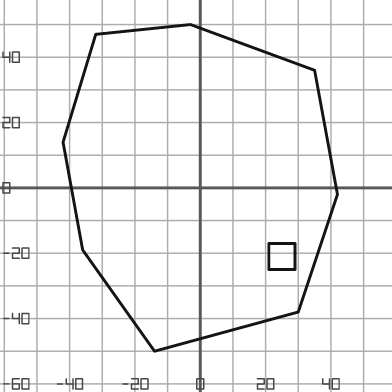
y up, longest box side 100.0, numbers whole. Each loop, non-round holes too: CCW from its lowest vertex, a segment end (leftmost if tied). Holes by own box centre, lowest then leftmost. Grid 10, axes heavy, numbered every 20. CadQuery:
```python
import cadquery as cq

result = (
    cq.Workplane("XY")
    .moveTo(-14.0, -50.0)
    .lineTo(30.0, -38.0)
    .lineTo(42.0, -2.0)
    .lineTo(35.0, 36.0)
    .lineTo(-3.0, 50.0)
    .lineTo(-32.0, 47.0)
    .lineTo(-42.0, 14.0)
    .lineTo(-36.0, -19.0)
    .close()
    .moveTo(21.0, -25.0)
    .lineTo(29.0, -25.0)
    .lineTo(29.0, -17.0)
    .lineTo(21.0, -17.0)
    .close()
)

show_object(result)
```